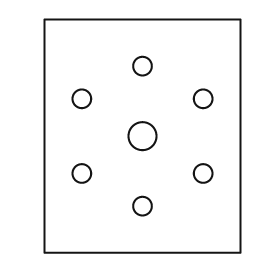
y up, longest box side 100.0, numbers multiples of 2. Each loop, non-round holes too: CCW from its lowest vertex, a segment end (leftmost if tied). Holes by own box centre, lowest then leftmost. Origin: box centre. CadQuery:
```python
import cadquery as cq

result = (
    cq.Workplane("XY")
    .moveTo(-42.0, -50.0)
    .lineTo(42.0, -50.0)
    .lineTo(42.0, 50.0)
    .lineTo(-42.0, 50.0)
    .close()
    .moveTo(0.0, -30.0)
    .circle(4.0)
    .moveTo(-26.0, -16.0)
    .circle(4.0)
    .moveTo(26.0, -16.0)
    .circle(4.0)
    .moveTo(0.0, 0.0)
    .circle(6.0)
    .moveTo(-26.0, 16.0)
    .circle(4.0)
    .moveTo(26.0, 16.0)
    .circle(4.0)
    .moveTo(0.0, 30.0)
    .circle(4.0)
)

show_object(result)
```